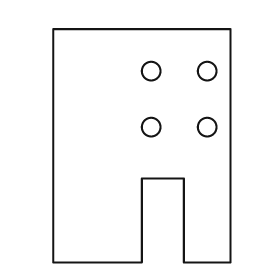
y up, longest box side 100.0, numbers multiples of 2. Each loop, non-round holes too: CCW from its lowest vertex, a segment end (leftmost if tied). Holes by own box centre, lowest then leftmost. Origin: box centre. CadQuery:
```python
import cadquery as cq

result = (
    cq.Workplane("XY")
    .moveTo(-38.0, -50.0)
    .lineTo(0.0, -50.0)
    .lineTo(0.0, -14.0)
    .lineTo(18.0, -14.0)
    .lineTo(18.0, -50.0)
    .lineTo(38.0, -50.0)
    .lineTo(38.0, 50.0)
    .lineTo(-38.0, 50.0)
    .close()
    .moveTo(4.0, 8.0)
    .circle(4.0)
    .moveTo(28.0, 8.0)
    .circle(4.0)
    .moveTo(4.0, 32.0)
    .circle(4.0)
    .moveTo(28.0, 32.0)
    .circle(4.0)
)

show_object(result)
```